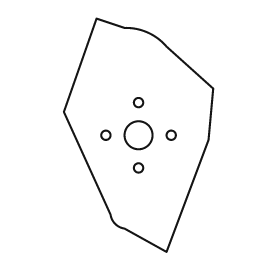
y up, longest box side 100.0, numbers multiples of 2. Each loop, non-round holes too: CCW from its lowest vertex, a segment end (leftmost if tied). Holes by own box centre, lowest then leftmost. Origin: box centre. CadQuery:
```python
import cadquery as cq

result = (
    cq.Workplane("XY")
    .moveTo(12.0, -50.0)
    .lineTo(30.0, -2.0)
    .lineTo(32.0, 20.0)
    .lineTo(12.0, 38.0)
    .threePointArc((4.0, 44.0), (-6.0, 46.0))
    .lineTo(-18.0, 50.0)
    .lineTo(-32.0, 10.0)
    .lineTo(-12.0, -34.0)
    .threePointArc((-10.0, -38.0), (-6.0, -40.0))
    .close()
    .moveTo(0.0, -14.0)
    .circle(2.0)
    .moveTo(-14.0, 0.0)
    .circle(2.0)
    .moveTo(0.0, 0.0)
    .circle(6.0)
    .moveTo(14.0, 0.0)
    .circle(2.0)
    .moveTo(0.0, 14.0)
    .circle(2.0)
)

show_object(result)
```